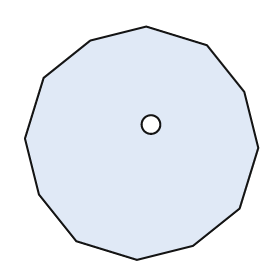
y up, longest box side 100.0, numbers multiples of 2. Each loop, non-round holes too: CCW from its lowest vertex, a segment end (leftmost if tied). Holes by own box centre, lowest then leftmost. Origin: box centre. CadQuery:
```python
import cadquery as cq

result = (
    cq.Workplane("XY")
    .moveTo(-2.0, -50.0)
    .lineTo(22.0, -44.0)
    .lineTo(42.0, -28.0)
    .lineTo(50.0, -2.0)
    .lineTo(44.0, 22.0)
    .lineTo(28.0, 42.0)
    .lineTo(2.0, 50.0)
    .lineTo(-22.0, 44.0)
    .lineTo(-42.0, 28.0)
    .lineTo(-50.0, 2.0)
    .lineTo(-44.0, -22.0)
    .lineTo(-28.0, -42.0)
    .close()
    .moveTo(4.0, 8.0)
    .circle(4.0)
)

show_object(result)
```